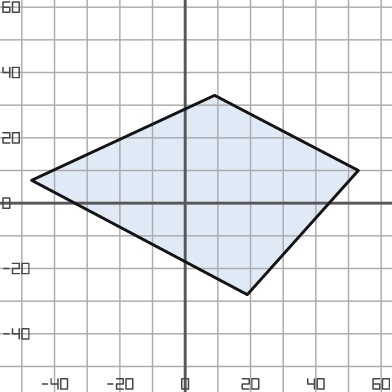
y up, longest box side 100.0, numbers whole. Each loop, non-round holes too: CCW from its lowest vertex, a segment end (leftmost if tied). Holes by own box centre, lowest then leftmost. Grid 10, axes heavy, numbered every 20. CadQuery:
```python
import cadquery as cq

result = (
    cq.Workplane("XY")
    .moveTo(19.0, -28.0)
    .lineTo(53.0, 10.0)
    .lineTo(9.0, 33.0)
    .lineTo(-47.0, 7.0)
    .close()
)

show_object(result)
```